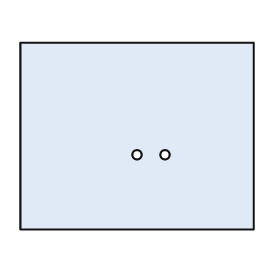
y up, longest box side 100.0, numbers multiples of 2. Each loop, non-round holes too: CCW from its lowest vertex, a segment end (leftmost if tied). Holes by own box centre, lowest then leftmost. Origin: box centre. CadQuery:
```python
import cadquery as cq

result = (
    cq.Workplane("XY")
    .moveTo(-50.0, -40.0)
    .lineTo(50.0, -40.0)
    .lineTo(50.0, 40.0)
    .lineTo(-50.0, 40.0)
    .close()
    .moveTo(0.0, -8.0)
    .circle(2.0)
    .moveTo(12.0, -8.0)
    .circle(2.0)
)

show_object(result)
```